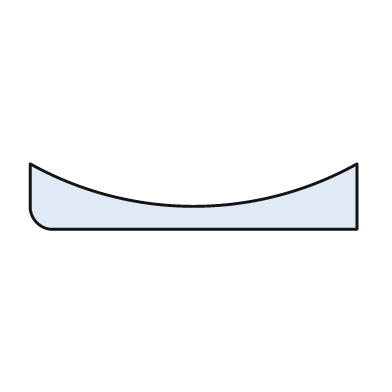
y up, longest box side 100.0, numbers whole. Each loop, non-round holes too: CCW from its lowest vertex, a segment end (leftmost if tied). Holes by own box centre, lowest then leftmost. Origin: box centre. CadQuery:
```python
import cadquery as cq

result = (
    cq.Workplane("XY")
    .moveTo(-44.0, -10.0)
    .lineTo(50.0, -10.0)
    .lineTo(50.0, 10.0)
    .threePointArc((0.0, -3.0), (-50.0, 10.0))
    .lineTo(-50.0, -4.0)
    .threePointArc((-48.0, -8.0), (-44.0, -10.0))
    .close()
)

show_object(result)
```